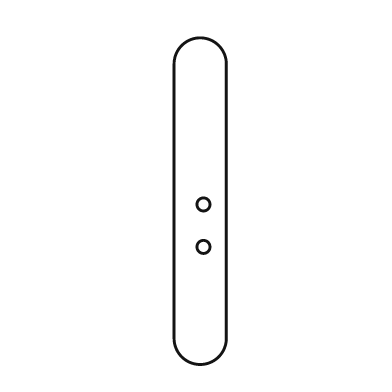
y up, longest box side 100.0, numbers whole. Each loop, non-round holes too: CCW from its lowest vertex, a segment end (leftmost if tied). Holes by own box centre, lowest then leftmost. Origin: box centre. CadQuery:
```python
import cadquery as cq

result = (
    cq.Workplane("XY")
    .moveTo(-8.0, -42.0)
    .threePointArc((0.0, -50.0), (8.0, -42.0))
    .lineTo(8.0, 42.0)
    .threePointArc((0.0, 50.0), (-8.0, 42.0))
    .close()
    .moveTo(1.0, -14.0)
    .circle(2.0)
    .moveTo(1.0, -1.0)
    .circle(2.0)
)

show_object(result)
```